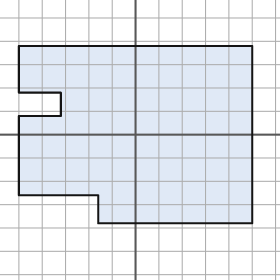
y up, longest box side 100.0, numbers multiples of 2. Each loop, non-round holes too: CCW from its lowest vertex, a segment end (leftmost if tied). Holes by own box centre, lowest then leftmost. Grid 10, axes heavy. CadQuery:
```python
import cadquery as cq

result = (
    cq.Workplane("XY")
    .moveTo(-16.0, -38.0)
    .lineTo(50.0, -38.0)
    .lineTo(50.0, 38.0)
    .lineTo(-50.0, 38.0)
    .lineTo(-50.0, 18.0)
    .lineTo(-32.0, 18.0)
    .lineTo(-32.0, 8.0)
    .lineTo(-50.0, 8.0)
    .lineTo(-50.0, -26.0)
    .lineTo(-16.0, -26.0)
    .close()
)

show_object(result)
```